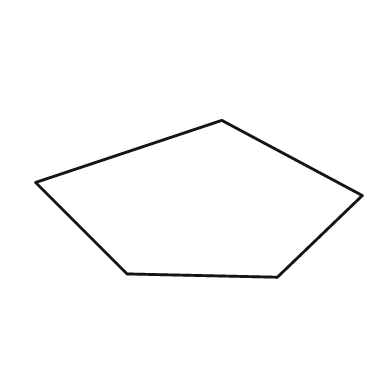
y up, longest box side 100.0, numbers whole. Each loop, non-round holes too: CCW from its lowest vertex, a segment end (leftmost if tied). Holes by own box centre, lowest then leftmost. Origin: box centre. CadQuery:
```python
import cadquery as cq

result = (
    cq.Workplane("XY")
    .moveTo(24.0, -24.0)
    .lineTo(50.0, 1.0)
    .lineTo(7.0, 24.0)
    .lineTo(-50.0, 5.0)
    .lineTo(-22.0, -23.0)
    .close()
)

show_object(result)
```